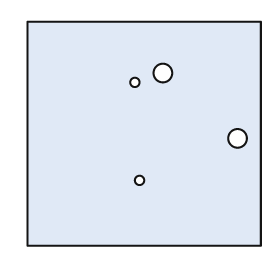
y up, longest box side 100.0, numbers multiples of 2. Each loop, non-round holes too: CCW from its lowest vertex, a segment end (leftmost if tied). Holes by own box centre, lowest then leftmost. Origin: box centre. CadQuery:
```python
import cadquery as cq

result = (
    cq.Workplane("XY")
    .moveTo(-50.0, -48.0)
    .lineTo(50.0, -48.0)
    .lineTo(50.0, 48.0)
    .lineTo(-50.0, 48.0)
    .close()
    .moveTo(-2.0, -20.0)
    .circle(2.0)
    .moveTo(40.0, -2.0)
    .circle(4.0)
    .moveTo(-4.0, 22.0)
    .circle(2.0)
    .moveTo(8.0, 26.0)
    .circle(4.0)
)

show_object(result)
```